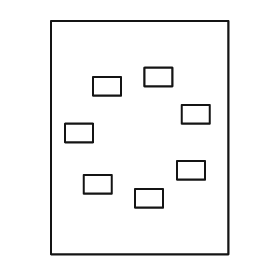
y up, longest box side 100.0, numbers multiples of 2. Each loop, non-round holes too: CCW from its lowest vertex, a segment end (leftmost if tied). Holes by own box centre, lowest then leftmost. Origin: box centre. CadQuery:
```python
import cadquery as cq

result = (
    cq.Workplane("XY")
    .moveTo(-38.0, -50.0)
    .lineTo(38.0, -50.0)
    .lineTo(38.0, 50.0)
    .lineTo(-38.0, 50.0)
    .close()
    .moveTo(-2.0, -30.0)
    .lineTo(10.0, -30.0)
    .lineTo(10.0, -22.0)
    .lineTo(-2.0, -22.0)
    .close()
    .moveTo(-24.0, -24.0)
    .lineTo(-12.0, -24.0)
    .lineTo(-12.0, -16.0)
    .lineTo(-24.0, -16.0)
    .close()
    .moveTo(16.0, -18.0)
    .lineTo(28.0, -18.0)
    .lineTo(28.0, -10.0)
    .lineTo(16.0, -10.0)
    .close()
    .moveTo(-32.0, -2.0)
    .lineTo(-20.0, -2.0)
    .lineTo(-20.0, 6.0)
    .lineTo(-32.0, 6.0)
    .close()
    .moveTo(18.0, 6.0)
    .lineTo(30.0, 6.0)
    .lineTo(30.0, 14.0)
    .lineTo(18.0, 14.0)
    .close()
    .moveTo(-20.0, 18.0)
    .lineTo(-8.0, 18.0)
    .lineTo(-8.0, 26.0)
    .lineTo(-20.0, 26.0)
    .close()
    .moveTo(2.0, 22.0)
    .lineTo(14.0, 22.0)
    .lineTo(14.0, 30.0)
    .lineTo(2.0, 30.0)
    .close()
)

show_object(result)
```